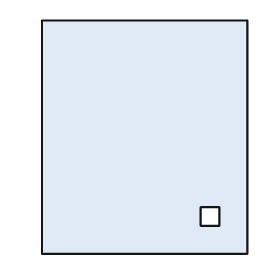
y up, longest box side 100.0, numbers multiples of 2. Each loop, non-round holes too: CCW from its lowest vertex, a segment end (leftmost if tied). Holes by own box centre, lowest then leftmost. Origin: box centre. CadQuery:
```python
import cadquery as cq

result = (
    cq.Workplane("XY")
    .moveTo(-44.0, -50.0)
    .lineTo(44.0, -50.0)
    .lineTo(44.0, 50.0)
    .lineTo(-44.0, 50.0)
    .close()
    .moveTo(24.0, -38.0)
    .lineTo(32.0, -38.0)
    .lineTo(32.0, -30.0)
    .lineTo(24.0, -30.0)
    .close()
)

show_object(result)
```